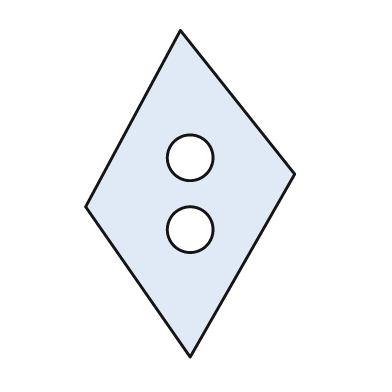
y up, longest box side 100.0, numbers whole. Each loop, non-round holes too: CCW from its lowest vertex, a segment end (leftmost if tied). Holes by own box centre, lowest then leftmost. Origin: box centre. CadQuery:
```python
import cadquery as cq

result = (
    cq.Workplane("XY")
    .moveTo(0.0, -50.0)
    .lineTo(32.0, 6.0)
    .lineTo(-3.0, 50.0)
    .lineTo(-32.0, -4.0)
    .close()
    .moveTo(0.0, -11.0)
    .circle(7.0)
    .moveTo(0.0, 11.0)
    .circle(7.0)
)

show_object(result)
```